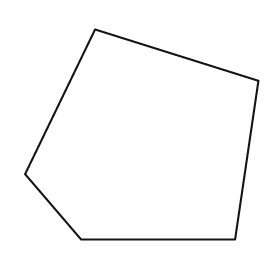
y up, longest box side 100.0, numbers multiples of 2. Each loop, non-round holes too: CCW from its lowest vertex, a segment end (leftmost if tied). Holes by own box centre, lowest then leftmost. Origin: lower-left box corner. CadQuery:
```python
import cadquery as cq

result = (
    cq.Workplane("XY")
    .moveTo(24.0, 0.0)
    .lineTo(90.0, 0.0)
    .lineTo(100.0, 68.0)
    .lineTo(30.0, 90.0)
    .lineTo(0.0, 28.0)
    .close()
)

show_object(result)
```